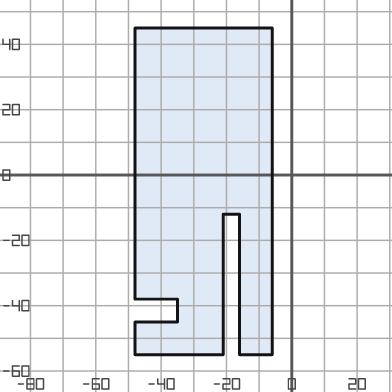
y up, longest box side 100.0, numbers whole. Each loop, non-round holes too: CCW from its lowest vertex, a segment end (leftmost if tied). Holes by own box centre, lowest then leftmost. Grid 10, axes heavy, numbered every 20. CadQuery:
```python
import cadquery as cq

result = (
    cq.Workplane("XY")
    .moveTo(-48.0, -55.0)
    .lineTo(-21.0, -55.0)
    .lineTo(-21.0, -12.0)
    .lineTo(-16.0, -12.0)
    .lineTo(-16.0, -55.0)
    .lineTo(-6.0, -55.0)
    .lineTo(-6.0, 45.0)
    .lineTo(-48.0, 45.0)
    .lineTo(-48.0, -38.0)
    .lineTo(-35.0, -38.0)
    .lineTo(-35.0, -45.0)
    .lineTo(-48.0, -45.0)
    .close()
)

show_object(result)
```